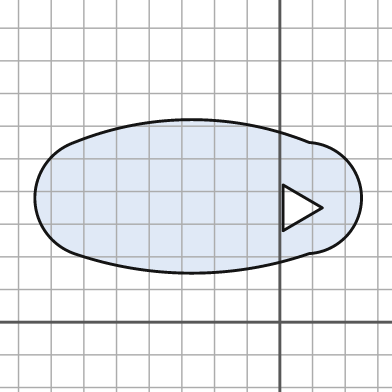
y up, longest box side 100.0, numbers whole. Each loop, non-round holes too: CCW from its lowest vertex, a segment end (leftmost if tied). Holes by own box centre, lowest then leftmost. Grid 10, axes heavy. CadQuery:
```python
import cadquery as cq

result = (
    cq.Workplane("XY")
    .moveTo(-63.0, 21.0)
    .threePointArc((-27.0, 15.0), (9.0, 21.0))
    .threePointArc((25.0, 38.0), (9.0, 55.0))
    .threePointArc((-27.0, 62.0), (-63.0, 55.0))
    .threePointArc((-75.0, 38.0), (-63.0, 21.0))
    .close()
    .moveTo(1.0, 28.0)
    .lineTo(13.0, 35.0)
    .lineTo(1.0, 42.0)
    .close()
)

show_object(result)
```